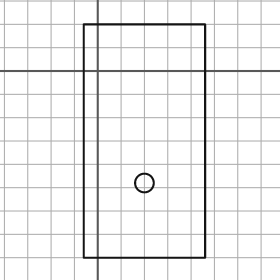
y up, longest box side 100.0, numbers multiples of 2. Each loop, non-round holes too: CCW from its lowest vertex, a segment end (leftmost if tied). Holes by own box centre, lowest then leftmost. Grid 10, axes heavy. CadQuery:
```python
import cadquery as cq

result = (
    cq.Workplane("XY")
    .moveTo(-6.0, -80.0)
    .lineTo(46.0, -80.0)
    .lineTo(46.0, 20.0)
    .lineTo(-6.0, 20.0)
    .close()
    .moveTo(20.0, -48.0)
    .circle(4.0)
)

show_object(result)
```